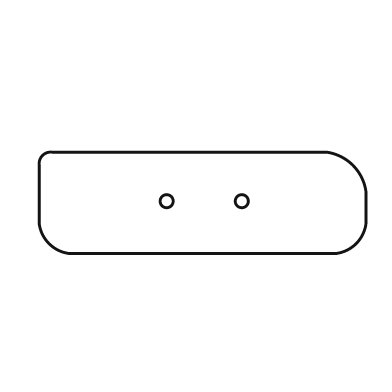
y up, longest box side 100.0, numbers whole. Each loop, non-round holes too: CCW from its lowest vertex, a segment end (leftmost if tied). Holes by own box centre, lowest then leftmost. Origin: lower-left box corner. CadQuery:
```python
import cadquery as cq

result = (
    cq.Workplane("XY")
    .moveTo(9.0, 0.0)
    .lineTo(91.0, 0.0)
    .threePointArc((97.0, 3.0), (100.0, 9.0))
    .lineTo(100.0, 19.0)
    .threePointArc((96.0, 27.0), (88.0, 31.0))
    .lineTo(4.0, 31.0)
    .threePointArc((1.0, 30.0), (0.0, 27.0))
    .lineTo(0.0, 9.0)
    .threePointArc((3.0, 3.0), (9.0, 0.0))
    .close()
    .moveTo(39.0, 16.0)
    .circle(2.0)
    .moveTo(62.0, 16.0)
    .circle(2.0)
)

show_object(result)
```